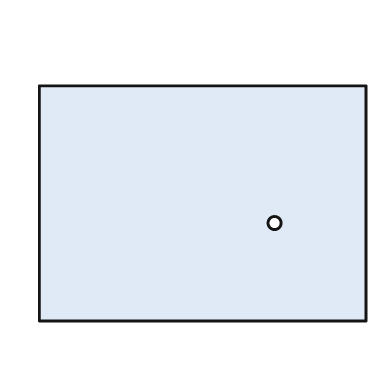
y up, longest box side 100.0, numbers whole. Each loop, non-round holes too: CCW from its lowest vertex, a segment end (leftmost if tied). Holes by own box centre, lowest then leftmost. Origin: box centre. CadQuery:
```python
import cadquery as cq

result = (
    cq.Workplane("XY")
    .moveTo(-50.0, -36.0)
    .lineTo(50.0, -36.0)
    .lineTo(50.0, 36.0)
    .lineTo(-50.0, 36.0)
    .close()
    .moveTo(22.0, -6.0)
    .circle(2.0)
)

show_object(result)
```